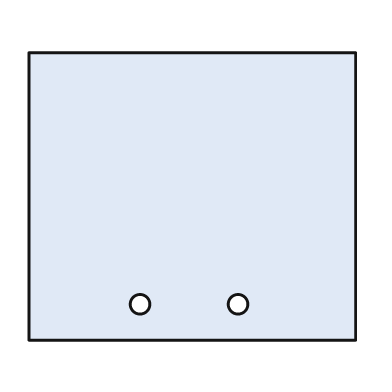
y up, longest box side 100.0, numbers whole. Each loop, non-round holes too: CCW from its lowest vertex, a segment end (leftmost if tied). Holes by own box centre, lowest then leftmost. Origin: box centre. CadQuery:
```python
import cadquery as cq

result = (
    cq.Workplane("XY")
    .moveTo(-50.0, -44.0)
    .lineTo(50.0, -44.0)
    .lineTo(50.0, 44.0)
    .lineTo(-50.0, 44.0)
    .close()
    .moveTo(-16.0, -33.0)
    .circle(3.0)
    .moveTo(14.0, -33.0)
    .circle(3.0)
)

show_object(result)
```